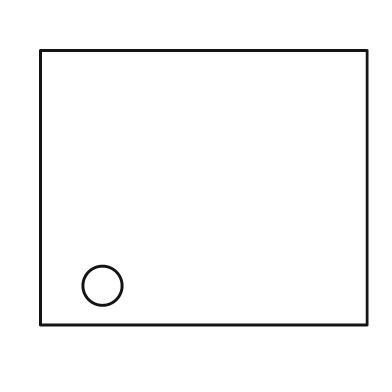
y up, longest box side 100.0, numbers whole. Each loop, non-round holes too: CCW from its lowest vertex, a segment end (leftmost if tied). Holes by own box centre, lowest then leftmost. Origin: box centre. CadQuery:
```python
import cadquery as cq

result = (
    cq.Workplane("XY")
    .moveTo(-50.0, -42.0)
    .lineTo(50.0, -42.0)
    .lineTo(50.0, 42.0)
    .lineTo(-50.0, 42.0)
    .close()
    .moveTo(-31.0, -30.0)
    .circle(6.0)
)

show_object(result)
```